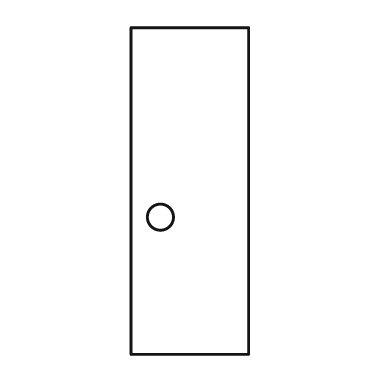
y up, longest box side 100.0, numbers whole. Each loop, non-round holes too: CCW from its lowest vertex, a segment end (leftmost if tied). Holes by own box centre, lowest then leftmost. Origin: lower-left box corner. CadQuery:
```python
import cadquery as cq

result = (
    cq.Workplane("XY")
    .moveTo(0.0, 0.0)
    .lineTo(36.0, 0.0)
    .lineTo(36.0, 100.0)
    .lineTo(0.0, 100.0)
    .close()
    .moveTo(9.0, 42.0)
    .circle(4.0)
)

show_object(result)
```